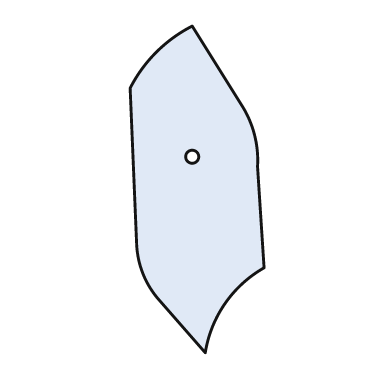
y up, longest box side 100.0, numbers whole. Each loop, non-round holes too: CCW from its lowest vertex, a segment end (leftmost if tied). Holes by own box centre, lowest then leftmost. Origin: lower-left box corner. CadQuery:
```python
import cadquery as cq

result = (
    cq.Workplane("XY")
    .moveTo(23.0, 0.0)
    .threePointArc((29.0, 15.0), (41.0, 26.0))
    .lineTo(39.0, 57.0)
    .threePointArc((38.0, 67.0), (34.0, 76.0))
    .lineTo(19.0, 100.0)
    .threePointArc((8.0, 92.0), (0.0, 81.0))
    .lineTo(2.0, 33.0)
    .threePointArc((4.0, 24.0), (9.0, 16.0))
    .close()
    .moveTo(19.0, 60.0)
    .circle(2.0)
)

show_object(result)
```